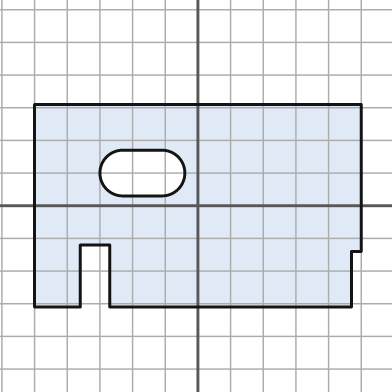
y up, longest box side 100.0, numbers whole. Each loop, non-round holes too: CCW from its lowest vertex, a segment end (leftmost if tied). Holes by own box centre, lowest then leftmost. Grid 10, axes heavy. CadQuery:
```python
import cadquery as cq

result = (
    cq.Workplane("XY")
    .moveTo(-50.0, -31.0)
    .lineTo(-36.0, -31.0)
    .lineTo(-36.0, -12.0)
    .lineTo(-27.0, -12.0)
    .lineTo(-27.0, -31.0)
    .lineTo(47.0, -31.0)
    .lineTo(47.0, -14.0)
    .lineTo(50.0, -14.0)
    .lineTo(50.0, 31.0)
    .lineTo(-50.0, 31.0)
    .close()
    .moveTo(-23.0, 3.0)
    .lineTo(-11.0, 3.0)
    .threePointArc((-4.0, 10.0), (-11.0, 17.0))
    .lineTo(-23.0, 17.0)
    .threePointArc((-30.0, 10.0), (-23.0, 3.0))
    .close()
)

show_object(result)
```